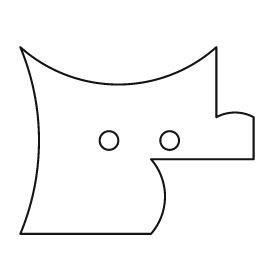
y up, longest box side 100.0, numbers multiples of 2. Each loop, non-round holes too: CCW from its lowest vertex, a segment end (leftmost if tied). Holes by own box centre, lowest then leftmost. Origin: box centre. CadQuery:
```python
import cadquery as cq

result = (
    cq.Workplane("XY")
    .moveTo(-50.0, -40.0)
    .lineTo(6.0, -40.0)
    .threePointArc((12.0, -24.0), (6.0, -8.0))
    .lineTo(50.0, -8.0)
    .lineTo(50.0, 10.0)
    .threePointArc((42.0, 12.0), (34.0, 10.0))
    .lineTo(34.0, 40.0)
    .threePointArc((-8.0, 24.0), (-50.0, 40.0))
    .threePointArc((-42.0, 0.0), (-50.0, -40.0))
    .close()
    .moveTo(-12.0, 0.0)
    .circle(4.0)
    .moveTo(14.0, 0.0)
    .circle(4.0)
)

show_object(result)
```